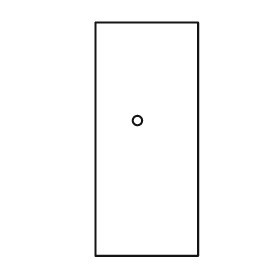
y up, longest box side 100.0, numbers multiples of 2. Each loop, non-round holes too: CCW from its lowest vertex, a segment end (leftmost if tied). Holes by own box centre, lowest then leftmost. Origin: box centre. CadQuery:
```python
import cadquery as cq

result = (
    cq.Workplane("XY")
    .moveTo(-22.0, -50.0)
    .lineTo(22.0, -50.0)
    .lineTo(22.0, 50.0)
    .lineTo(-22.0, 50.0)
    .close()
    .moveTo(-4.0, 8.0)
    .circle(2.0)
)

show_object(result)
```